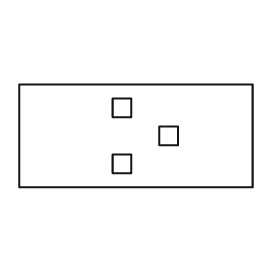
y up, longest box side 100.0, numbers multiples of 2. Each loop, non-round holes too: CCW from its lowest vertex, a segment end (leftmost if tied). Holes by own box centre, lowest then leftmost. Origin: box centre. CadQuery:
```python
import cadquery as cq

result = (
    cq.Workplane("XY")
    .moveTo(-50.0, -22.0)
    .lineTo(50.0, -22.0)
    .lineTo(50.0, 22.0)
    .lineTo(-50.0, 22.0)
    .close()
    .moveTo(-10.0, -16.0)
    .lineTo(-2.0, -16.0)
    .lineTo(-2.0, -8.0)
    .lineTo(-10.0, -8.0)
    .close()
    .moveTo(10.0, -4.0)
    .lineTo(18.0, -4.0)
    .lineTo(18.0, 4.0)
    .lineTo(10.0, 4.0)
    .close()
    .moveTo(-10.0, 8.0)
    .lineTo(-2.0, 8.0)
    .lineTo(-2.0, 16.0)
    .lineTo(-10.0, 16.0)
    .close()
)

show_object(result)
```